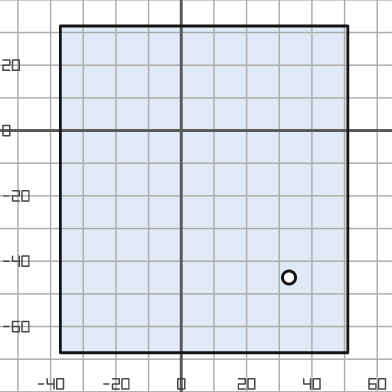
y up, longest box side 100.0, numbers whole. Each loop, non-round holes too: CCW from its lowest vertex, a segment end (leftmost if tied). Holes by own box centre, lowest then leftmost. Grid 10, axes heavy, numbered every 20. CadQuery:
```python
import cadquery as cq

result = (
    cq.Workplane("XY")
    .moveTo(-37.0, -68.0)
    .lineTo(51.0, -68.0)
    .lineTo(51.0, 32.0)
    .lineTo(-37.0, 32.0)
    .close()
    .moveTo(33.0, -45.0)
    .circle(2.0)
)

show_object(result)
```